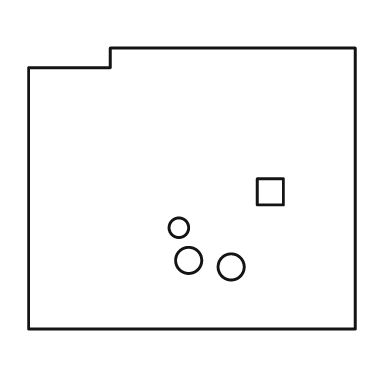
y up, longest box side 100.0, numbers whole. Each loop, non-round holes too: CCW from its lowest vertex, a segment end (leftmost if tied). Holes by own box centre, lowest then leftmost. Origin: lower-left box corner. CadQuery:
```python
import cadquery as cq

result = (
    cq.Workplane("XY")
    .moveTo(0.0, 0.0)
    .lineTo(100.0, 0.0)
    .lineTo(100.0, 86.0)
    .lineTo(25.0, 86.0)
    .lineTo(25.0, 80.0)
    .lineTo(0.0, 80.0)
    .close()
    .moveTo(62.0, 19.0)
    .circle(4.0)
    .moveTo(49.0, 21.0)
    .circle(4.0)
    .moveTo(46.0, 31.0)
    .circle(3.0)
    .moveTo(70.0, 38.0)
    .lineTo(78.0, 38.0)
    .lineTo(78.0, 46.0)
    .lineTo(70.0, 46.0)
    .close()
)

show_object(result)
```